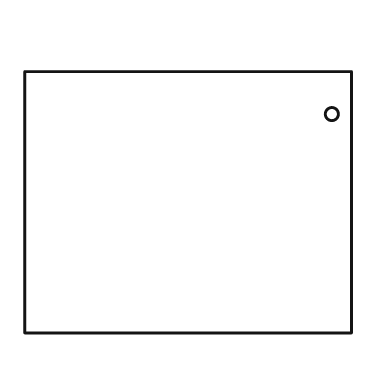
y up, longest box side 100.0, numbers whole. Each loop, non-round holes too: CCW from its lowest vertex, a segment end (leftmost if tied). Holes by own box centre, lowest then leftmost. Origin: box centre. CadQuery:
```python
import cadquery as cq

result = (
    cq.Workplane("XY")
    .moveTo(-50.0, -40.0)
    .lineTo(50.0, -40.0)
    .lineTo(50.0, 40.0)
    .lineTo(-50.0, 40.0)
    .close()
    .moveTo(44.0, 27.0)
    .circle(2.0)
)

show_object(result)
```